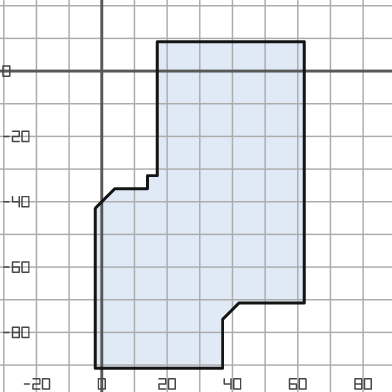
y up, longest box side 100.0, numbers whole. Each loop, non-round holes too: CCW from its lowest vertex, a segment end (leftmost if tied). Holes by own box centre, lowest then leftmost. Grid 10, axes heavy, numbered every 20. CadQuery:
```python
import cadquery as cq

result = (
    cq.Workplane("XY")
    .moveTo(-2.0, -91.0)
    .lineTo(37.0, -91.0)
    .lineTo(37.0, -76.0)
    .lineTo(42.0, -71.0)
    .lineTo(62.0, -71.0)
    .lineTo(62.0, 9.0)
    .lineTo(17.0, 9.0)
    .lineTo(17.0, -32.0)
    .lineTo(14.0, -32.0)
    .lineTo(14.0, -36.0)
    .lineTo(4.0, -36.0)
    .lineTo(-2.0, -42.0)
    .close()
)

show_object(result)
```